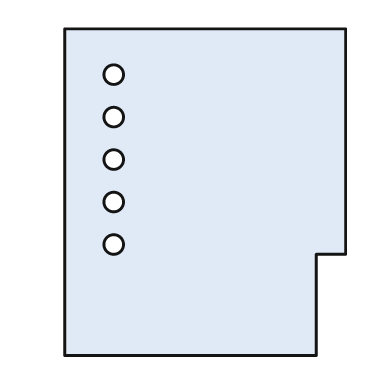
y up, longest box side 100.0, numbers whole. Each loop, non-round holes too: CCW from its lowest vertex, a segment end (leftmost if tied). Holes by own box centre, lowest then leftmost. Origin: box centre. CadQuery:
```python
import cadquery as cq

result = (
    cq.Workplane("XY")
    .moveTo(-43.0, -50.0)
    .lineTo(34.0, -50.0)
    .lineTo(34.0, -19.0)
    .lineTo(43.0, -19.0)
    .lineTo(43.0, 50.0)
    .lineTo(-43.0, 50.0)
    .close()
    .moveTo(-28.0, -16.0)
    .circle(3.0)
    .moveTo(-28.0, -3.0)
    .circle(3.0)
    .moveTo(-28.0, 10.0)
    .circle(3.0)
    .moveTo(-28.0, 23.0)
    .circle(3.0)
    .moveTo(-28.0, 36.0)
    .circle(3.0)
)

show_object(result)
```